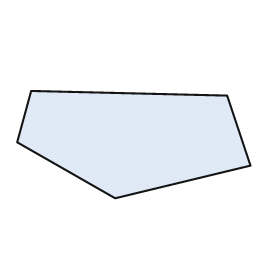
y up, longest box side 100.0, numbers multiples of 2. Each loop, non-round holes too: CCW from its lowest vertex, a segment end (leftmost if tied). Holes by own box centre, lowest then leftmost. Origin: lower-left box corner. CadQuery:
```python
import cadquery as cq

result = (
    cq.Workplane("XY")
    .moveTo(42.0, 0.0)
    .lineTo(100.0, 14.0)
    .lineTo(90.0, 44.0)
    .lineTo(6.0, 46.0)
    .lineTo(0.0, 24.0)
    .close()
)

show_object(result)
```